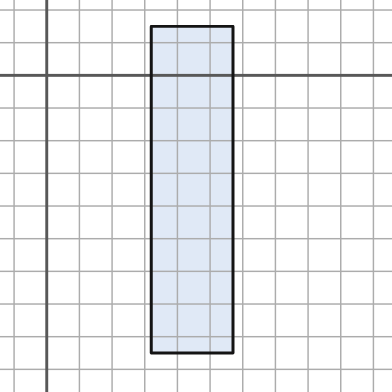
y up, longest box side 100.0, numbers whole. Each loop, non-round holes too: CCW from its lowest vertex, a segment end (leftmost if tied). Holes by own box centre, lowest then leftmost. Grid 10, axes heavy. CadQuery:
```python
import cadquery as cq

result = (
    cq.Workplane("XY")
    .moveTo(32.0, -85.0)
    .lineTo(57.0, -85.0)
    .lineTo(57.0, 15.0)
    .lineTo(32.0, 15.0)
    .close()
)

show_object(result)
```